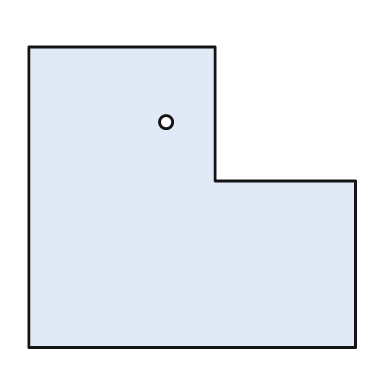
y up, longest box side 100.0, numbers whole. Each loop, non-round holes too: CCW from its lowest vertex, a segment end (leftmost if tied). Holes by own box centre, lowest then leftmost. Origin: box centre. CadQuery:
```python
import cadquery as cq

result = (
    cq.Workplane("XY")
    .moveTo(-50.0, -46.0)
    .lineTo(50.0, -46.0)
    .lineTo(50.0, 5.0)
    .lineTo(7.0, 5.0)
    .lineTo(7.0, 46.0)
    .lineTo(-50.0, 46.0)
    .close()
    .moveTo(-8.0, 23.0)
    .circle(2.0)
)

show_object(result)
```